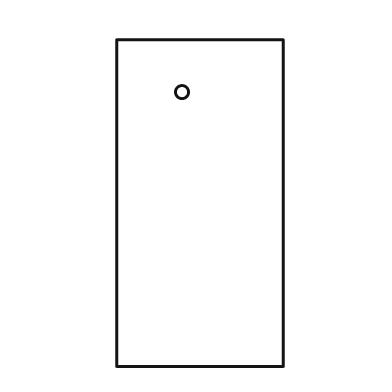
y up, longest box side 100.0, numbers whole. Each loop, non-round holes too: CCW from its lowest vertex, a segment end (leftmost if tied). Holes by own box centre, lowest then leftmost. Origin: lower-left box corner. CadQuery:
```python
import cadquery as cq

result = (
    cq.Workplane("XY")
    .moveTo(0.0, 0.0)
    .lineTo(51.0, 0.0)
    .lineTo(51.0, 100.0)
    .lineTo(0.0, 100.0)
    .close()
    .moveTo(20.0, 84.0)
    .circle(2.0)
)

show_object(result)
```